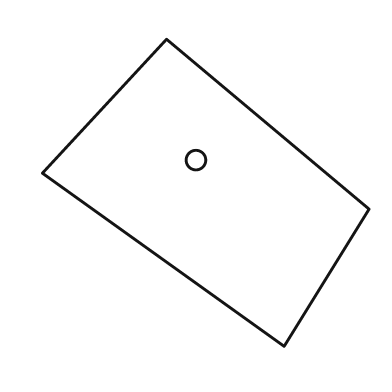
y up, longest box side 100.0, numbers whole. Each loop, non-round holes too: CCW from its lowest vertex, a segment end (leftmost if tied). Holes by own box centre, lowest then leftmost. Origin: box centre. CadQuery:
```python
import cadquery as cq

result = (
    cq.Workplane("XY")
    .moveTo(24.0, -47.0)
    .lineTo(50.0, -5.0)
    .lineTo(-12.0, 47.0)
    .lineTo(-50.0, 6.0)
    .close()
    .moveTo(-3.0, 10.0)
    .circle(3.0)
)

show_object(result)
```